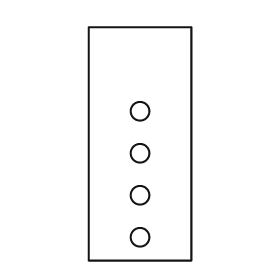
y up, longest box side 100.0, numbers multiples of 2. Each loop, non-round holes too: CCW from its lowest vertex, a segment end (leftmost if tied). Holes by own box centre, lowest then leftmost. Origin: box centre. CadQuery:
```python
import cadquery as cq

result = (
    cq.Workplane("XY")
    .moveTo(-22.0, -50.0)
    .lineTo(22.0, -50.0)
    .lineTo(22.0, 50.0)
    .lineTo(-22.0, 50.0)
    .close()
    .moveTo(0.0, -40.0)
    .circle(4.0)
    .moveTo(0.0, -22.0)
    .circle(4.0)
    .moveTo(0.0, -4.0)
    .circle(4.0)
    .moveTo(0.0, 14.0)
    .circle(4.0)
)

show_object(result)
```